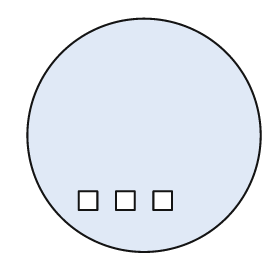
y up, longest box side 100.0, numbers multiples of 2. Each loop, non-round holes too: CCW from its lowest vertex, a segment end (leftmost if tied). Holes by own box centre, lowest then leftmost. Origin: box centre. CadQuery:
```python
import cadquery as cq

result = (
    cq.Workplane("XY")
    .moveTo(0.0, 0.0)
    .circle(50.0)
    .moveTo(-28.0, -32.0)
    .lineTo(-20.0, -32.0)
    .lineTo(-20.0, -24.0)
    .lineTo(-28.0, -24.0)
    .close()
    .moveTo(-12.0, -32.0)
    .lineTo(-4.0, -32.0)
    .lineTo(-4.0, -24.0)
    .lineTo(-12.0, -24.0)
    .close()
    .moveTo(4.0, -32.0)
    .lineTo(12.0, -32.0)
    .lineTo(12.0, -24.0)
    .lineTo(4.0, -24.0)
    .close()
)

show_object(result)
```